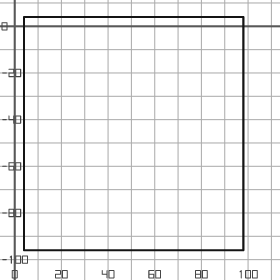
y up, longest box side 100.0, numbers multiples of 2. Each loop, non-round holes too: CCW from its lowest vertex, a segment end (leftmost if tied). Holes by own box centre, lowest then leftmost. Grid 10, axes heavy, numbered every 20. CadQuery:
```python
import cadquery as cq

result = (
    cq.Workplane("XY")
    .moveTo(4.0, -96.0)
    .lineTo(98.0, -96.0)
    .lineTo(98.0, 4.0)
    .lineTo(4.0, 4.0)
    .close()
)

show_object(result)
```